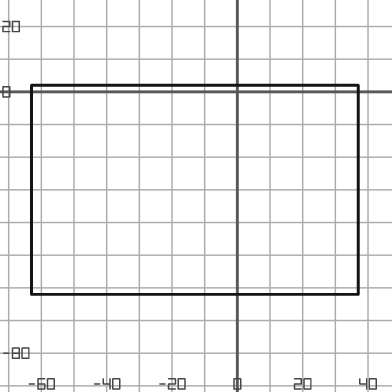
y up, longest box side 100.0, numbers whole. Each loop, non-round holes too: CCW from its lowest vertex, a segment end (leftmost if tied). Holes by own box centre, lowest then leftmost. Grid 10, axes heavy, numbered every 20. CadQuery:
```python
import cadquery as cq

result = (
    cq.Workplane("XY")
    .moveTo(-63.0, -62.0)
    .lineTo(37.0, -62.0)
    .lineTo(37.0, 2.0)
    .lineTo(-63.0, 2.0)
    .close()
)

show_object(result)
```